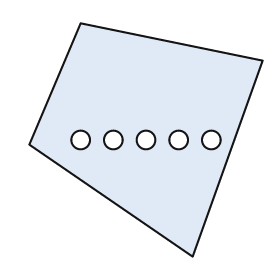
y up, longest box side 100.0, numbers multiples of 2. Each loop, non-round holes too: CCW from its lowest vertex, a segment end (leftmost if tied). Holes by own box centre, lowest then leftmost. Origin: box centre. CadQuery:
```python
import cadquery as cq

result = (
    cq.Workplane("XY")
    .moveTo(20.0, -50.0)
    .lineTo(50.0, 34.0)
    .lineTo(-28.0, 50.0)
    .lineTo(-50.0, -2.0)
    .close()
    .moveTo(-28.0, 0.0)
    .circle(4.0)
    .moveTo(-14.0, 0.0)
    .circle(4.0)
    .moveTo(0.0, 0.0)
    .circle(4.0)
    .moveTo(14.0, 0.0)
    .circle(4.0)
    .moveTo(28.0, 0.0)
    .circle(4.0)
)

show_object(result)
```